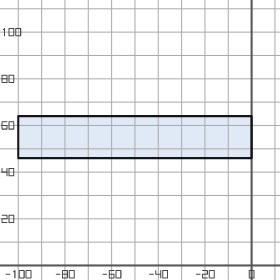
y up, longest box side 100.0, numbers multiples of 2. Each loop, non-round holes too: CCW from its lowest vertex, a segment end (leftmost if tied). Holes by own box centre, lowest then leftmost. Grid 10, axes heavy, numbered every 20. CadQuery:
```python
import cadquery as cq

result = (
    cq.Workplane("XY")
    .moveTo(-100.0, 46.0)
    .lineTo(0.0, 46.0)
    .lineTo(0.0, 64.0)
    .lineTo(-100.0, 64.0)
    .close()
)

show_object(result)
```